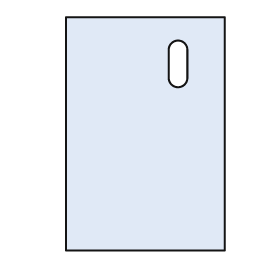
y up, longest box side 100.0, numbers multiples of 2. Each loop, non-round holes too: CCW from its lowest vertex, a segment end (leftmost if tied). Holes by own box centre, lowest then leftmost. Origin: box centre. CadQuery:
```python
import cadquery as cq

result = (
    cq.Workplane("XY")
    .moveTo(-34.0, -50.0)
    .lineTo(34.0, -50.0)
    .lineTo(34.0, 50.0)
    .lineTo(-34.0, 50.0)
    .close()
    .moveTo(10.0, 24.0)
    .threePointArc((14.0, 20.0), (18.0, 24.0))
    .lineTo(18.0, 36.0)
    .threePointArc((14.0, 40.0), (10.0, 36.0))
    .close()
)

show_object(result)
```